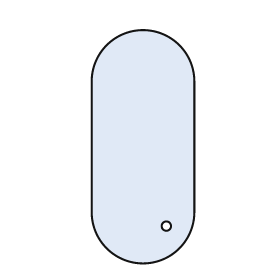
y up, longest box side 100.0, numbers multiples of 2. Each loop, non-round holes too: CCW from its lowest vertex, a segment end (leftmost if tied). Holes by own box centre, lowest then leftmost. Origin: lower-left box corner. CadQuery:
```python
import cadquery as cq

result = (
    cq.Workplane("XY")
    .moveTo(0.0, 22.0)
    .threePointArc((22.0, 0.0), (44.0, 22.0))
    .lineTo(44.0, 78.0)
    .threePointArc((22.0, 100.0), (0.0, 78.0))
    .close()
    .moveTo(32.0, 16.0)
    .circle(2.0)
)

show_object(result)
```